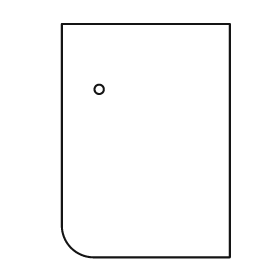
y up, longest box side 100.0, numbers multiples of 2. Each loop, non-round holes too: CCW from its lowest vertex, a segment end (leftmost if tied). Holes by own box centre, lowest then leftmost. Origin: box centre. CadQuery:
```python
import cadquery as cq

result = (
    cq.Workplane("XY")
    .moveTo(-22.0, -50.0)
    .lineTo(36.0, -50.0)
    .lineTo(36.0, 50.0)
    .lineTo(-36.0, 50.0)
    .lineTo(-36.0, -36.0)
    .threePointArc((-32.0, -46.0), (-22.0, -50.0))
    .close()
    .moveTo(-20.0, 22.0)
    .circle(2.0)
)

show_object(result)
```